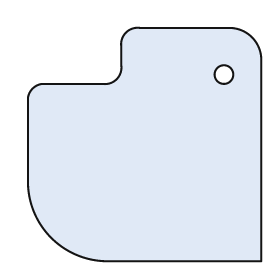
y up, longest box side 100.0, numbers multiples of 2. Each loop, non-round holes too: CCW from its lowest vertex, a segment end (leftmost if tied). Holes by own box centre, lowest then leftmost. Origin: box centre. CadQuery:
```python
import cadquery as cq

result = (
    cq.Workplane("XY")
    .moveTo(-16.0, -50.0)
    .lineTo(50.0, -50.0)
    .lineTo(50.0, 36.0)
    .threePointArc((46.0, 46.0), (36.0, 50.0))
    .lineTo(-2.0, 50.0)
    .threePointArc((-8.0, 48.0), (-10.0, 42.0))
    .lineTo(-10.0, 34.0)
    .threePointArc((-12.0, 28.0), (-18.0, 26.0))
    .lineTo(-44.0, 26.0)
    .threePointArc((-48.0, 24.0), (-50.0, 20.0))
    .lineTo(-50.0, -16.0)
    .threePointArc((-40.0, -40.0), (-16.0, -50.0))
    .close()
    .moveTo(34.0, 30.0)
    .circle(4.0)
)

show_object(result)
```